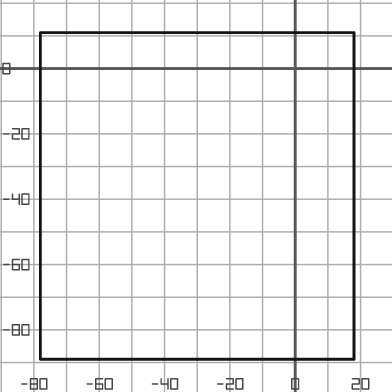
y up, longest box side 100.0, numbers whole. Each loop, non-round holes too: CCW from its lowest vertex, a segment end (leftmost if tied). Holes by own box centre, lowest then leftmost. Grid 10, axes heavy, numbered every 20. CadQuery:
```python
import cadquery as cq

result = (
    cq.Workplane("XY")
    .moveTo(-78.0, -89.0)
    .lineTo(18.0, -89.0)
    .lineTo(18.0, 11.0)
    .lineTo(-78.0, 11.0)
    .close()
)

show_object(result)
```